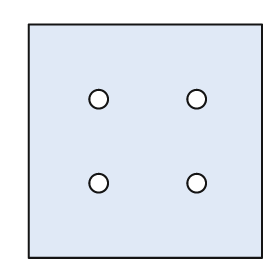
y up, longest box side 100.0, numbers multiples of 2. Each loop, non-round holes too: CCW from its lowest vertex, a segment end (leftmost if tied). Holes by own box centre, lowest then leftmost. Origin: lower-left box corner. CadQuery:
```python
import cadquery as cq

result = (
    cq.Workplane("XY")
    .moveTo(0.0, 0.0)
    .lineTo(100.0, 0.0)
    .lineTo(100.0, 100.0)
    .lineTo(0.0, 100.0)
    .close()
    .moveTo(30.0, 32.0)
    .circle(4.0)
    .moveTo(72.0, 32.0)
    .circle(4.0)
    .moveTo(30.0, 68.0)
    .circle(4.0)
    .moveTo(72.0, 68.0)
    .circle(4.0)
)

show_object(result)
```